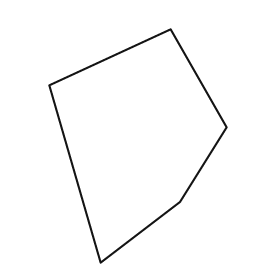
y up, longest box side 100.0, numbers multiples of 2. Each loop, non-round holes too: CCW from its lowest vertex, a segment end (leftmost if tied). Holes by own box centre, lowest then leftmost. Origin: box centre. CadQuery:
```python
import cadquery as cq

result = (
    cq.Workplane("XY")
    .moveTo(-16.0, -50.0)
    .lineTo(18.0, -24.0)
    .lineTo(38.0, 8.0)
    .lineTo(14.0, 50.0)
    .lineTo(-38.0, 26.0)
    .close()
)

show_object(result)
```